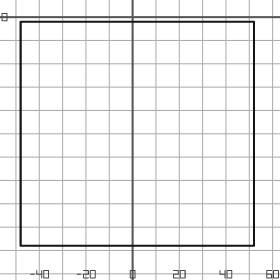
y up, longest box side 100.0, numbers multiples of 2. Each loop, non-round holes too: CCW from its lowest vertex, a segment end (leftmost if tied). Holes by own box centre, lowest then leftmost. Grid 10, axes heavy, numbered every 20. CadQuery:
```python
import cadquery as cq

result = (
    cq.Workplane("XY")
    .moveTo(-48.0, -98.0)
    .lineTo(52.0, -98.0)
    .lineTo(52.0, -2.0)
    .lineTo(-48.0, -2.0)
    .close()
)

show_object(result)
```